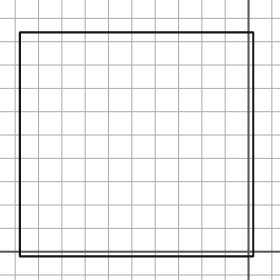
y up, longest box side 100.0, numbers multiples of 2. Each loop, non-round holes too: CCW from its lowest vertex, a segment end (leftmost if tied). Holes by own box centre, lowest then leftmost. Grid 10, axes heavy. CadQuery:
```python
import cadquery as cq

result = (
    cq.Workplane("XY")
    .moveTo(-98.0, -2.0)
    .lineTo(2.0, -2.0)
    .lineTo(2.0, 94.0)
    .lineTo(-98.0, 94.0)
    .close()
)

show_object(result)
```